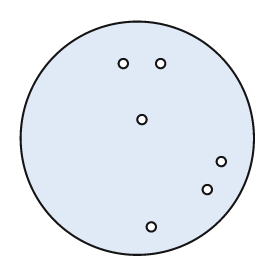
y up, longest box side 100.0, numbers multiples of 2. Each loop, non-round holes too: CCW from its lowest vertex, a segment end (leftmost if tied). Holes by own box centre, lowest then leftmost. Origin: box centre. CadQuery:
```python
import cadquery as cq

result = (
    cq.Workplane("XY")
    .moveTo(0.0, 0.0)
    .circle(50.0)
    .moveTo(6.0, -38.0)
    .circle(2.0)
    .moveTo(30.0, -22.0)
    .circle(2.0)
    .moveTo(36.0, -10.0)
    .circle(2.0)
    .moveTo(2.0, 8.0)
    .circle(2.0)
    .moveTo(-6.0, 32.0)
    .circle(2.0)
    .moveTo(10.0, 32.0)
    .circle(2.0)
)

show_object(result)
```